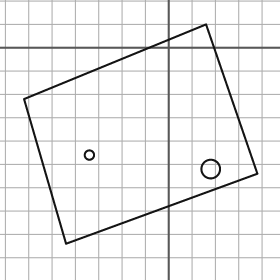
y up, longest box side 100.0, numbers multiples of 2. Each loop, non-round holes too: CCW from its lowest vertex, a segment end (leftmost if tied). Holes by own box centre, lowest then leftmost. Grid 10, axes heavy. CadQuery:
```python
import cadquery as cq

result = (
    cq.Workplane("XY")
    .moveTo(-44.0, -84.0)
    .lineTo(38.0, -54.0)
    .lineTo(16.0, 10.0)
    .lineTo(-62.0, -22.0)
    .close()
    .moveTo(18.0, -52.0)
    .circle(4.0)
    .moveTo(-34.0, -46.0)
    .circle(2.0)
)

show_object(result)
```